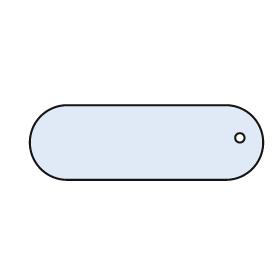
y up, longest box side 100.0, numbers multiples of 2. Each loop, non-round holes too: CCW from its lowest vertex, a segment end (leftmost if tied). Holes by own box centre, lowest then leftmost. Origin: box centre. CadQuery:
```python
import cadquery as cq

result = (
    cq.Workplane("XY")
    .moveTo(-34.0, -16.0)
    .lineTo(34.0, -16.0)
    .threePointArc((50.0, 0.0), (34.0, 16.0))
    .lineTo(-34.0, 16.0)
    .threePointArc((-50.0, 0.0), (-34.0, -16.0))
    .close()
    .moveTo(40.0, 2.0)
    .circle(2.0)
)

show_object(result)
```